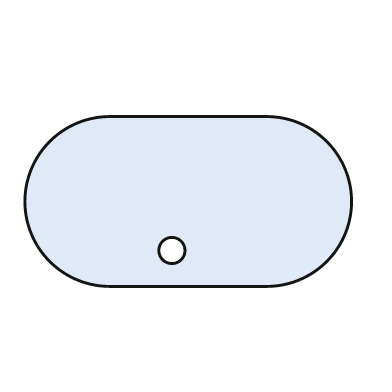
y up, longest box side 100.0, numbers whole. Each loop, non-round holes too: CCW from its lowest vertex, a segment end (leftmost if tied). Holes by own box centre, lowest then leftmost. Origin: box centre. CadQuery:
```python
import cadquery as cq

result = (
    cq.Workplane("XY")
    .moveTo(-24.0, -26.0)
    .lineTo(24.0, -26.0)
    .threePointArc((50.0, 0.0), (24.0, 26.0))
    .lineTo(-24.0, 26.0)
    .threePointArc((-50.0, 0.0), (-24.0, -26.0))
    .close()
    .moveTo(-5.0, -15.0)
    .circle(4.0)
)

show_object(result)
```